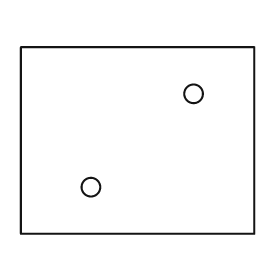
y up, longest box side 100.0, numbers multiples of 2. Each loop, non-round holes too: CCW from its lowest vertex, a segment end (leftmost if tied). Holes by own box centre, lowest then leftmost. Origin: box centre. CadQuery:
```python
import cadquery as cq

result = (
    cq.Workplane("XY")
    .moveTo(-50.0, -40.0)
    .lineTo(50.0, -40.0)
    .lineTo(50.0, 40.0)
    .lineTo(-50.0, 40.0)
    .close()
    .moveTo(-20.0, -20.0)
    .circle(4.0)
    .moveTo(24.0, 20.0)
    .circle(4.0)
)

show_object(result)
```